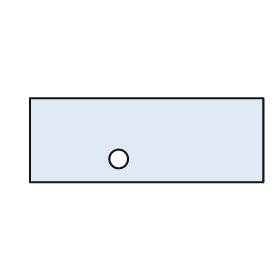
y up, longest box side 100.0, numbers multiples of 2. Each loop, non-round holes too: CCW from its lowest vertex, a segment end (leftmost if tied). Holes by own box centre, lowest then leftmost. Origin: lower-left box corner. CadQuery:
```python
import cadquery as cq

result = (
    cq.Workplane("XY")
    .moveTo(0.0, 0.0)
    .lineTo(100.0, 0.0)
    .lineTo(100.0, 36.0)
    .lineTo(0.0, 36.0)
    .close()
    .moveTo(38.0, 10.0)
    .circle(4.0)
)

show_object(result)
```